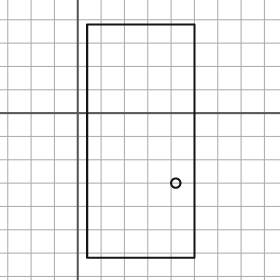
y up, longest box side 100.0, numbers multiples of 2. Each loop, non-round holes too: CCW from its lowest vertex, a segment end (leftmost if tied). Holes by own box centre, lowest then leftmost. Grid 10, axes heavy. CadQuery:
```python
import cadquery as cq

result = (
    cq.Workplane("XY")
    .moveTo(4.0, -62.0)
    .lineTo(50.0, -62.0)
    .lineTo(50.0, 38.0)
    .lineTo(4.0, 38.0)
    .close()
    .moveTo(42.0, -30.0)
    .circle(2.0)
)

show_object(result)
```